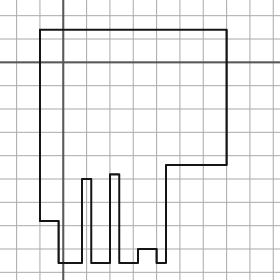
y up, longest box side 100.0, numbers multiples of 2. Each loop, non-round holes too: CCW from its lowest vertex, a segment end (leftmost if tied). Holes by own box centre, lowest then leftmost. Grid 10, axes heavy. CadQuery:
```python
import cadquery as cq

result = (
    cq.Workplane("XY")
    .moveTo(-2.0, -86.0)
    .lineTo(8.0, -86.0)
    .lineTo(8.0, -50.0)
    .lineTo(12.0, -50.0)
    .lineTo(12.0, -86.0)
    .lineTo(20.0, -86.0)
    .lineTo(20.0, -48.0)
    .lineTo(24.0, -48.0)
    .lineTo(24.0, -86.0)
    .lineTo(32.0, -86.0)
    .lineTo(32.0, -80.0)
    .lineTo(40.0, -80.0)
    .lineTo(40.0, -86.0)
    .lineTo(44.0, -86.0)
    .lineTo(44.0, -44.0)
    .lineTo(70.0, -44.0)
    .lineTo(70.0, 14.0)
    .lineTo(-10.0, 14.0)
    .lineTo(-10.0, -68.0)
    .lineTo(-2.0, -68.0)
    .close()
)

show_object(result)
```